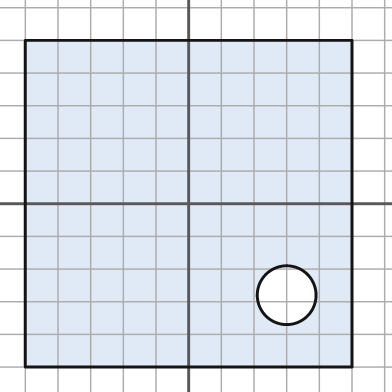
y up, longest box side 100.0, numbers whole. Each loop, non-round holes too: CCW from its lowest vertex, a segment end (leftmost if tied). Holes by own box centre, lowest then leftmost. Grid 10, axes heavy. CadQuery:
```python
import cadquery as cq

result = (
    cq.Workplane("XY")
    .moveTo(-50.0, -50.0)
    .lineTo(50.0, -50.0)
    .lineTo(50.0, 50.0)
    .lineTo(-50.0, 50.0)
    .close()
    .moveTo(30.0, -28.0)
    .circle(9.0)
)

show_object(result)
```